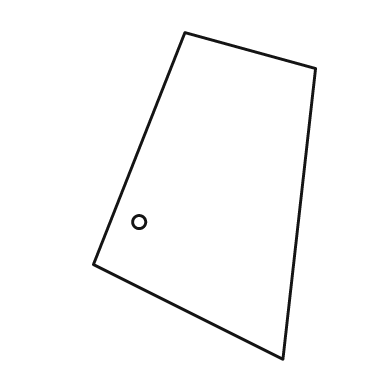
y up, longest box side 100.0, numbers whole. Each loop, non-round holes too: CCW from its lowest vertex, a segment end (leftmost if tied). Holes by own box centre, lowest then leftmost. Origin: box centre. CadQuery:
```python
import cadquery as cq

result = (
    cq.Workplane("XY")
    .moveTo(24.0, -50.0)
    .lineTo(34.0, 39.0)
    .lineTo(-6.0, 50.0)
    .lineTo(-34.0, -21.0)
    .close()
    .moveTo(-20.0, -8.0)
    .circle(2.0)
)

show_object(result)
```